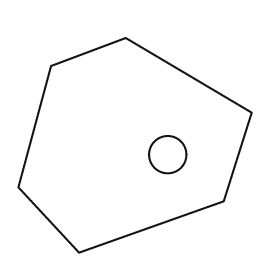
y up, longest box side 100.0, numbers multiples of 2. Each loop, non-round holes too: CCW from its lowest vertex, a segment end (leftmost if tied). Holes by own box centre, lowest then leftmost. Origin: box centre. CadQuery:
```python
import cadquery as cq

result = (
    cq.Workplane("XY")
    .moveTo(-24.0, -46.0)
    .lineTo(38.0, -24.0)
    .lineTo(50.0, 14.0)
    .lineTo(-4.0, 46.0)
    .lineTo(-36.0, 34.0)
    .lineTo(-50.0, -18.0)
    .close()
    .moveTo(14.0, -4.0)
    .circle(8.0)
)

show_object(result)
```